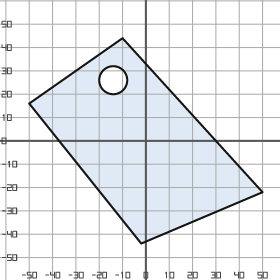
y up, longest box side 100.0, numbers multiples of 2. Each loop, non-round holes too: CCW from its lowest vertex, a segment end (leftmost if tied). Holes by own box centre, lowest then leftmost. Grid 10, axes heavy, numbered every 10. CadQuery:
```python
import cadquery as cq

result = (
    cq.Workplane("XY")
    .moveTo(-2.0, -44.0)
    .lineTo(50.0, -22.0)
    .lineTo(-10.0, 44.0)
    .lineTo(-50.0, 16.0)
    .close()
    .moveTo(-14.0, 26.0)
    .circle(6.0)
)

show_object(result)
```